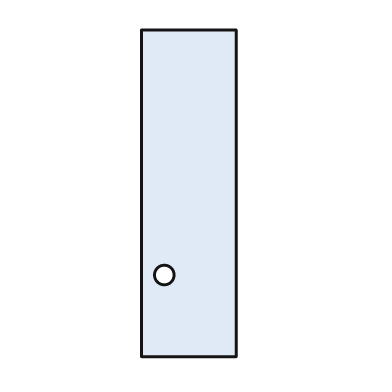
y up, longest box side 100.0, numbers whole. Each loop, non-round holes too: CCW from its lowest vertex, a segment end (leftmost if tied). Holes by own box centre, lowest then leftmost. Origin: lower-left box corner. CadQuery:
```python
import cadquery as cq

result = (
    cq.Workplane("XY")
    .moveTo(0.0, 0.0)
    .lineTo(29.0, 0.0)
    .lineTo(29.0, 100.0)
    .lineTo(0.0, 100.0)
    .close()
    .moveTo(7.0, 25.0)
    .circle(3.0)
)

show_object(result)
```